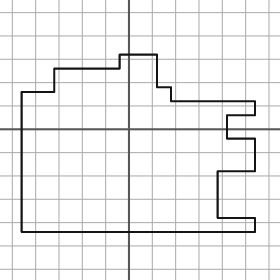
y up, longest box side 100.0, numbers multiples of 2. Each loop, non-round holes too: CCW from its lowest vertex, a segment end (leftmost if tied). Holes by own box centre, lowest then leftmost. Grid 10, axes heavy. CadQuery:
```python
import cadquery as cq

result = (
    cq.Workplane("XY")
    .moveTo(-46.0, -44.0)
    .lineTo(54.0, -44.0)
    .lineTo(54.0, -38.0)
    .lineTo(38.0, -38.0)
    .lineTo(38.0, -18.0)
    .lineTo(54.0, -18.0)
    .lineTo(54.0, -4.0)
    .lineTo(42.0, -4.0)
    .lineTo(42.0, 6.0)
    .lineTo(54.0, 6.0)
    .lineTo(54.0, 12.0)
    .lineTo(18.0, 12.0)
    .lineTo(18.0, 18.0)
    .lineTo(12.0, 18.0)
    .lineTo(12.0, 32.0)
    .lineTo(-4.0, 32.0)
    .lineTo(-4.0, 26.0)
    .lineTo(-32.0, 26.0)
    .lineTo(-32.0, 16.0)
    .lineTo(-46.0, 16.0)
    .close()
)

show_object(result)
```